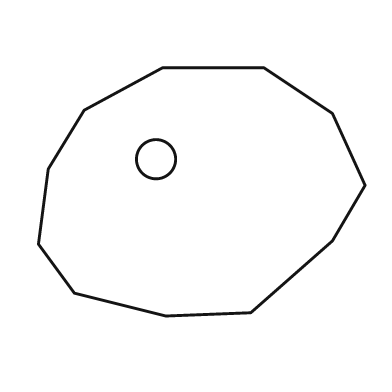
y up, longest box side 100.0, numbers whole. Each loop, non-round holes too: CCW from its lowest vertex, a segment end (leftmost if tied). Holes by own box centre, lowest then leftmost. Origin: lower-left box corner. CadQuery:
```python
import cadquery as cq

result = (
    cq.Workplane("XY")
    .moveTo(39.0, 0.0)
    .lineTo(65.0, 1.0)
    .lineTo(90.0, 23.0)
    .lineTo(100.0, 40.0)
    .lineTo(90.0, 62.0)
    .lineTo(69.0, 76.0)
    .lineTo(38.0, 76.0)
    .lineTo(14.0, 63.0)
    .lineTo(3.0, 45.0)
    .lineTo(0.0, 22.0)
    .lineTo(11.0, 7.0)
    .close()
    .moveTo(36.0, 48.0)
    .circle(6.0)
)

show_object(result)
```